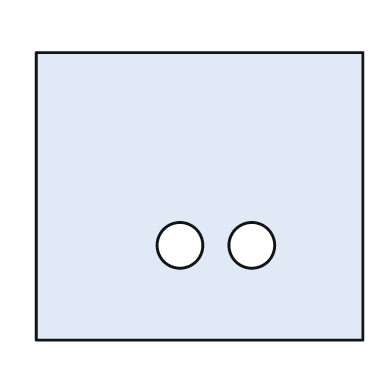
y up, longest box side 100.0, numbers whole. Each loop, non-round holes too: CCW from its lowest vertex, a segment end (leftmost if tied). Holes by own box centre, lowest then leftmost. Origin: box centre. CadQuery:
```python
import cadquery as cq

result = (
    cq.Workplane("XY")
    .moveTo(-50.0, -44.0)
    .lineTo(50.0, -44.0)
    .lineTo(50.0, 44.0)
    .lineTo(-50.0, 44.0)
    .close()
    .moveTo(-6.0, -15.0)
    .circle(7.0)
    .moveTo(16.0, -15.0)
    .circle(7.0)
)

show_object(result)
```